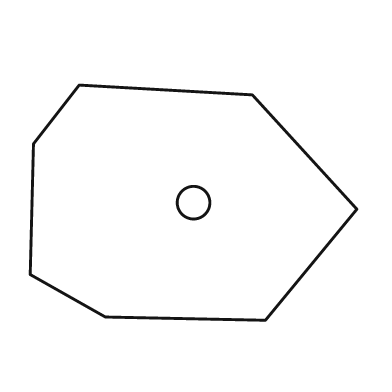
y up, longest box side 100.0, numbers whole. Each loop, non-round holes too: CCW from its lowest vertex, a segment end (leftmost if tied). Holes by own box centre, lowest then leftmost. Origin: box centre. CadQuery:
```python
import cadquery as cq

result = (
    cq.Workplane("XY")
    .moveTo(22.0, -36.0)
    .lineTo(50.0, -2.0)
    .lineTo(18.0, 33.0)
    .lineTo(-35.0, 36.0)
    .lineTo(-49.0, 18.0)
    .lineTo(-50.0, -22.0)
    .lineTo(-27.0, -35.0)
    .close()
    .moveTo(0.0, 0.0)
    .circle(5.0)
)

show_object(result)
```